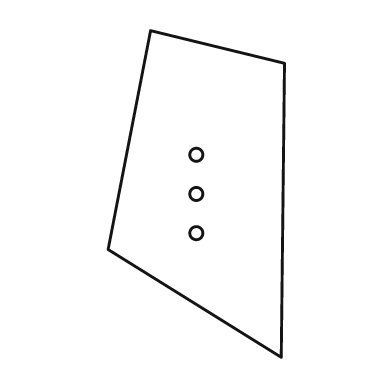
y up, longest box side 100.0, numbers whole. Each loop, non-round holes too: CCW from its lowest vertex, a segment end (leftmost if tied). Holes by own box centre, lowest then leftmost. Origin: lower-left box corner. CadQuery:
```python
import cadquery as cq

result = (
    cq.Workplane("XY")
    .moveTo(53.0, 0.0)
    .lineTo(54.0, 90.0)
    .lineTo(13.0, 100.0)
    .lineTo(0.0, 33.0)
    .close()
    .moveTo(27.0, 38.0)
    .circle(2.0)
    .moveTo(27.0, 50.0)
    .circle(2.0)
    .moveTo(27.0, 62.0)
    .circle(2.0)
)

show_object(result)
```